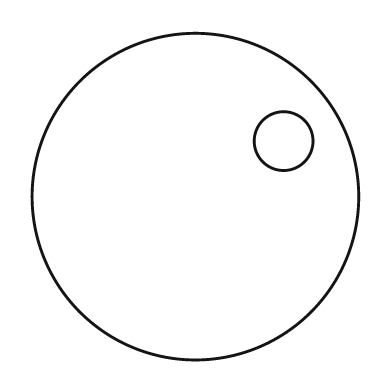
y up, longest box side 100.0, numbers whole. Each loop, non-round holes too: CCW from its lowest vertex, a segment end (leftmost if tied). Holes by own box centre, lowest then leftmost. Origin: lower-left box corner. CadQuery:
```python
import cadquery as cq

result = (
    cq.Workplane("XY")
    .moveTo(50.0, 50.0)
    .circle(50.0)
    .moveTo(77.0, 67.0)
    .circle(9.0)
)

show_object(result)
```